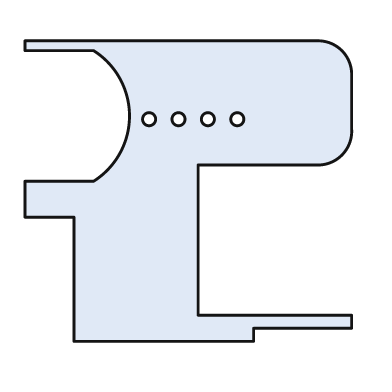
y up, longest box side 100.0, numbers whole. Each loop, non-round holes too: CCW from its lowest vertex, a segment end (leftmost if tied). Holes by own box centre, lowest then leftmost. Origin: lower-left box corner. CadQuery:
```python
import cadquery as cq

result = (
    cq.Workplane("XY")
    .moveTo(15.0, 0.0)
    .lineTo(70.0, 0.0)
    .lineTo(70.0, 4.0)
    .lineTo(100.0, 4.0)
    .lineTo(100.0, 8.0)
    .lineTo(53.0, 8.0)
    .lineTo(53.0, 54.0)
    .lineTo(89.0, 54.0)
    .threePointArc((97.0, 57.0), (100.0, 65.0))
    .lineTo(100.0, 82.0)
    .threePointArc((97.0, 89.0), (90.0, 92.0))
    .lineTo(0.0, 92.0)
    .lineTo(0.0, 89.0)
    .lineTo(21.0, 89.0)
    .threePointArc((32.0, 69.0), (21.0, 49.0))
    .lineTo(0.0, 49.0)
    .lineTo(0.0, 38.0)
    .lineTo(15.0, 38.0)
    .close()
    .moveTo(38.0, 68.0)
    .circle(2.0)
    .moveTo(47.0, 68.0)
    .circle(2.0)
    .moveTo(56.0, 68.0)
    .circle(2.0)
    .moveTo(65.0, 68.0)
    .circle(2.0)
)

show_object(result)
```